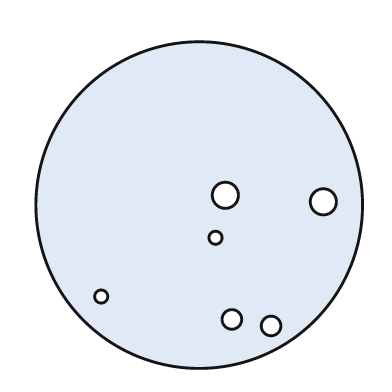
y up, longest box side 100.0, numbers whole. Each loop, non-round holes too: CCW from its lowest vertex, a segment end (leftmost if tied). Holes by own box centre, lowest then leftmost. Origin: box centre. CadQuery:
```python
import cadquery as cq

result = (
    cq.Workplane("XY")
    .moveTo(0.0, 0.0)
    .circle(50.0)
    .moveTo(22.0, -37.0)
    .circle(3.0)
    .moveTo(10.0, -35.0)
    .circle(3.0)
    .moveTo(-30.0, -28.0)
    .circle(2.0)
    .moveTo(5.0, -10.0)
    .circle(2.0)
    .moveTo(38.0, 1.0)
    .circle(4.0)
    .moveTo(8.0, 3.0)
    .circle(4.0)
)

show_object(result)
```